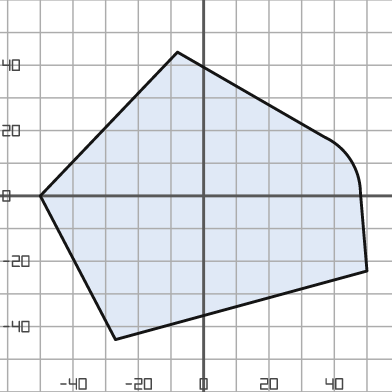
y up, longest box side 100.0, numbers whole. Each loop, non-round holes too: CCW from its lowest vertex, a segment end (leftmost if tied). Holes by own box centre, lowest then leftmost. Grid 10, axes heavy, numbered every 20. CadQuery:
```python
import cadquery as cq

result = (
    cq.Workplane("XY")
    .moveTo(-27.0, -44.0)
    .lineTo(50.0, -23.0)
    .lineTo(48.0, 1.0)
    .threePointArc((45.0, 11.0), (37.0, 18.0))
    .lineTo(-8.0, 44.0)
    .lineTo(-50.0, 0.0)
    .close()
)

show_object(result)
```